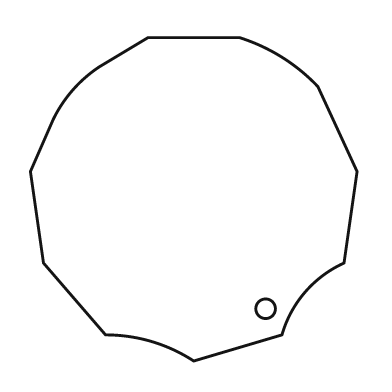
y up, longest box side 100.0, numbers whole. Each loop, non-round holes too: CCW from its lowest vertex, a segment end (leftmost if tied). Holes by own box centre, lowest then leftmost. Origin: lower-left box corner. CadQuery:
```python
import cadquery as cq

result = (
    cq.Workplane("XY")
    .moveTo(50.0, 0.0)
    .lineTo(77.0, 8.0)
    .threePointArc((84.0, 21.0), (96.0, 30.0))
    .lineTo(100.0, 58.0)
    .lineTo(88.0, 84.0)
    .threePointArc((77.0, 93.0), (64.0, 99.0))
    .lineTo(36.0, 99.0)
    .lineTo(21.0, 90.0)
    .threePointArc((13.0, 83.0), (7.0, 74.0))
    .lineTo(0.0, 58.0)
    .lineTo(4.0, 30.0)
    .lineTo(23.0, 8.0)
    .threePointArc((37.0, 6.0), (50.0, 0.0))
    .close()
    .moveTo(72.0, 16.0)
    .circle(3.0)
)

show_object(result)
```